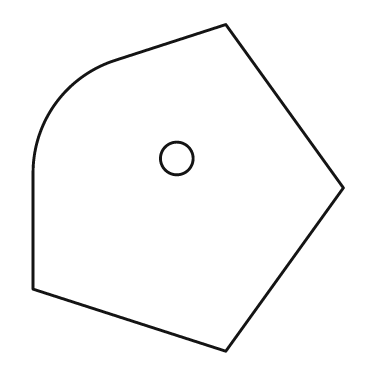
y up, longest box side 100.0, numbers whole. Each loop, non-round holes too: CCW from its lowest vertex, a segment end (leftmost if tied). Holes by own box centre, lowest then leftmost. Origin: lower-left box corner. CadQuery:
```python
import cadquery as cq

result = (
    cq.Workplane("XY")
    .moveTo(59.0, 0.0)
    .lineTo(95.0, 50.0)
    .lineTo(59.0, 100.0)
    .lineTo(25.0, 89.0)
    .threePointArc((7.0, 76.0), (0.0, 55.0))
    .lineTo(0.0, 19.0)
    .close()
    .moveTo(44.0, 59.0)
    .circle(5.0)
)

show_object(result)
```